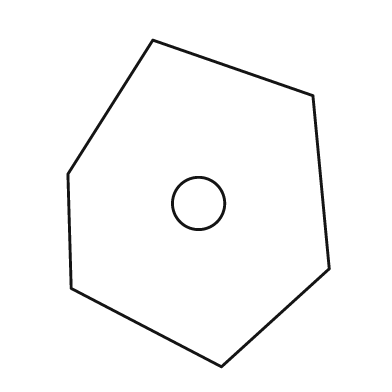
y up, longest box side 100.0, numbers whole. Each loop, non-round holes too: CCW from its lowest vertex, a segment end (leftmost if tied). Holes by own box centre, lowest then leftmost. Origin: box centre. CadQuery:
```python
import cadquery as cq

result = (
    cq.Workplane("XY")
    .moveTo(7.0, -50.0)
    .lineTo(40.0, -20.0)
    .lineTo(35.0, 33.0)
    .lineTo(-14.0, 50.0)
    .lineTo(-40.0, 9.0)
    .lineTo(-39.0, -26.0)
    .close()
    .moveTo(0.0, 0.0)
    .circle(8.0)
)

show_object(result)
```